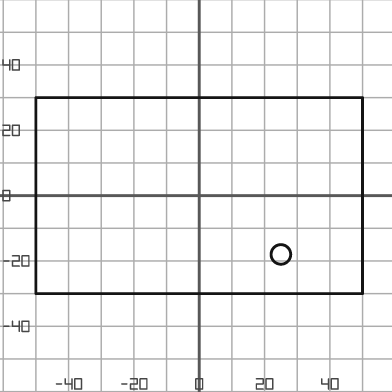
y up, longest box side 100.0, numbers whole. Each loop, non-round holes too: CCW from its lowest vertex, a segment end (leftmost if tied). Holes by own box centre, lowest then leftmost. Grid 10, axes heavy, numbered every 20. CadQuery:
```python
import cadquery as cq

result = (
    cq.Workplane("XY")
    .moveTo(-50.0, -30.0)
    .lineTo(50.0, -30.0)
    .lineTo(50.0, 30.0)
    .lineTo(-50.0, 30.0)
    .close()
    .moveTo(25.0, -18.0)
    .circle(3.0)
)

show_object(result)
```